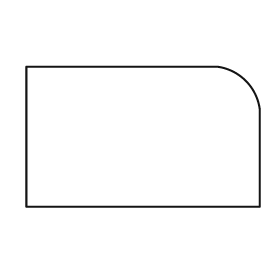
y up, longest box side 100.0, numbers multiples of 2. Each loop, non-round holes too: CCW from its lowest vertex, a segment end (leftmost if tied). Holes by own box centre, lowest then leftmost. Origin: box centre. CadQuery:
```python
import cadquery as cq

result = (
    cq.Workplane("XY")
    .moveTo(-50.0, -30.0)
    .lineTo(50.0, -30.0)
    .lineTo(50.0, 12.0)
    .threePointArc((44.0, 24.0), (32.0, 30.0))
    .lineTo(-50.0, 30.0)
    .close()
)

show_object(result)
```